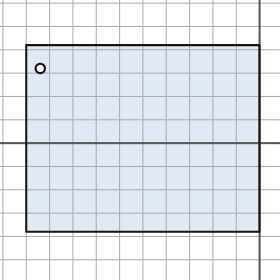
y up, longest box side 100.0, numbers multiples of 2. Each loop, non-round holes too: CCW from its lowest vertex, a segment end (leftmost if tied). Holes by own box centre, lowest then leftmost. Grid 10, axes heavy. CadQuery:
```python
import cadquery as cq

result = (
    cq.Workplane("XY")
    .moveTo(-100.0, -38.0)
    .lineTo(0.0, -38.0)
    .lineTo(0.0, 42.0)
    .lineTo(-100.0, 42.0)
    .close()
    .moveTo(-94.0, 32.0)
    .circle(2.0)
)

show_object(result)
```